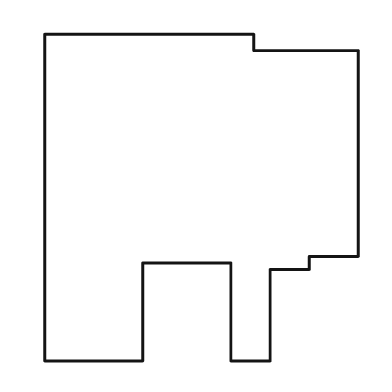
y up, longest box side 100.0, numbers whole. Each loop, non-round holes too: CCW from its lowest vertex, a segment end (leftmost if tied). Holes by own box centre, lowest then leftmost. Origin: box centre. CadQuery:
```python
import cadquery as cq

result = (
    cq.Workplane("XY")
    .moveTo(-48.0, -50.0)
    .lineTo(-18.0, -50.0)
    .lineTo(-18.0, -20.0)
    .lineTo(9.0, -20.0)
    .lineTo(9.0, -50.0)
    .lineTo(21.0, -50.0)
    .lineTo(21.0, -22.0)
    .lineTo(33.0, -22.0)
    .lineTo(33.0, -18.0)
    .lineTo(48.0, -18.0)
    .lineTo(48.0, 45.0)
    .lineTo(16.0, 45.0)
    .lineTo(16.0, 50.0)
    .lineTo(-48.0, 50.0)
    .close()
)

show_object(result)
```